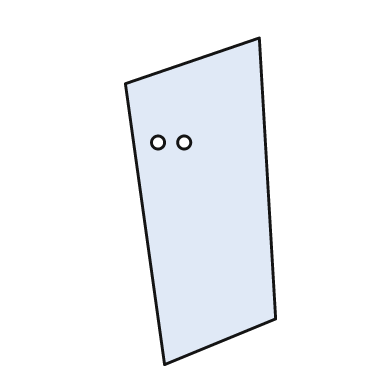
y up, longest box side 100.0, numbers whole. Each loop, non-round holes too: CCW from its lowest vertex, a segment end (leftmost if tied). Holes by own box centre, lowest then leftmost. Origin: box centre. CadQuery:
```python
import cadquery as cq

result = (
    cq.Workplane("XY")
    .moveTo(-11.0, -50.0)
    .lineTo(23.0, -36.0)
    .lineTo(18.0, 50.0)
    .lineTo(-23.0, 36.0)
    .close()
    .moveTo(-13.0, 18.0)
    .circle(2.0)
    .moveTo(-5.0, 18.0)
    .circle(2.0)
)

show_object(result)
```